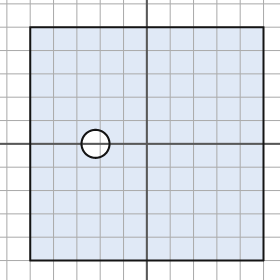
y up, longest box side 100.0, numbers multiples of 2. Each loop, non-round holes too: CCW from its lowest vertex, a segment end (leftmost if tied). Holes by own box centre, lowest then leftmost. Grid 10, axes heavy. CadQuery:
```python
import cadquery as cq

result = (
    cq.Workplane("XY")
    .moveTo(-50.0, -50.0)
    .lineTo(50.0, -50.0)
    .lineTo(50.0, 50.0)
    .lineTo(-50.0, 50.0)
    .close()
    .moveTo(-22.0, 0.0)
    .circle(6.0)
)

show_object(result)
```